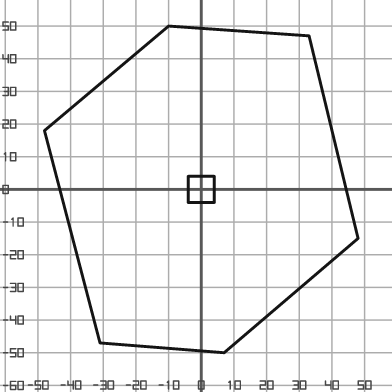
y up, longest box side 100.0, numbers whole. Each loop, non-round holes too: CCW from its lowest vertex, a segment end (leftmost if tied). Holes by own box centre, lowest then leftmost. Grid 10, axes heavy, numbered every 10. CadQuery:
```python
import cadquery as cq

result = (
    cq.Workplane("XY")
    .moveTo(7.0, -50.0)
    .lineTo(48.0, -15.0)
    .lineTo(33.0, 47.0)
    .lineTo(-10.0, 50.0)
    .lineTo(-48.0, 18.0)
    .lineTo(-31.0, -47.0)
    .close()
    .moveTo(-4.0, -4.0)
    .lineTo(4.0, -4.0)
    .lineTo(4.0, 4.0)
    .lineTo(-4.0, 4.0)
    .close()
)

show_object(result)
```